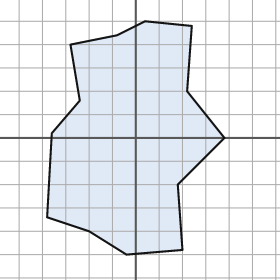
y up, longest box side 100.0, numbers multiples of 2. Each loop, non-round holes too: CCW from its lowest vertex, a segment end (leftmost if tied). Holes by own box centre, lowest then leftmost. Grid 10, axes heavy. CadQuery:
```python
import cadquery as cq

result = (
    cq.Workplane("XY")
    .moveTo(-4.0, -50.0)
    .lineTo(20.0, -48.0)
    .lineTo(18.0, -20.0)
    .lineTo(38.0, 0.0)
    .lineTo(22.0, 20.0)
    .lineTo(24.0, 48.0)
    .lineTo(4.0, 50.0)
    .lineTo(-8.0, 44.0)
    .lineTo(-28.0, 40.0)
    .lineTo(-24.0, 16.0)
    .lineTo(-36.0, 2.0)
    .lineTo(-38.0, -34.0)
    .lineTo(-20.0, -40.0)
    .close()
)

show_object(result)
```